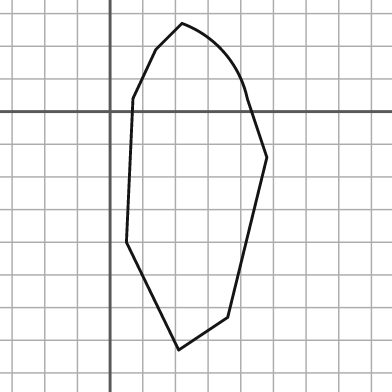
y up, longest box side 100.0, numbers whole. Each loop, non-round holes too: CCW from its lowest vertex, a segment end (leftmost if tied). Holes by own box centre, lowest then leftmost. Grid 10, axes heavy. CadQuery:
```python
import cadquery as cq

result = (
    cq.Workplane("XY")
    .moveTo(21.0, -73.0)
    .lineTo(36.0, -63.0)
    .lineTo(48.0, -14.0)
    .lineTo(42.0, 4.0)
    .threePointArc((35.0, 18.0), (22.0, 27.0))
    .lineTo(14.0, 19.0)
    .lineTo(7.0, 4.0)
    .lineTo(5.0, -40.0)
    .close()
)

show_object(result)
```